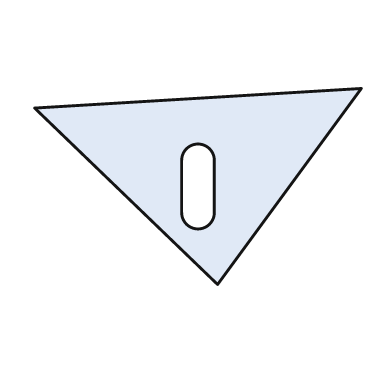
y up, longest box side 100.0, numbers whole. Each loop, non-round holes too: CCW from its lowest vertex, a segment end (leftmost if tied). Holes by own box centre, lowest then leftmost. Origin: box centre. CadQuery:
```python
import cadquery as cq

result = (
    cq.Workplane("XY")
    .moveTo(6.0, -30.0)
    .lineTo(50.0, 30.0)
    .lineTo(-50.0, 24.0)
    .close()
    .moveTo(-5.0, -8.0)
    .threePointArc((0.0, -13.0), (5.0, -8.0))
    .lineTo(5.0, 8.0)
    .threePointArc((0.0, 13.0), (-5.0, 8.0))
    .close()
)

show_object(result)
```